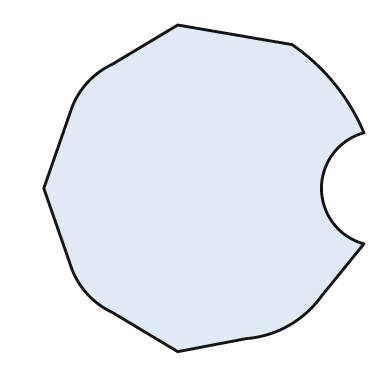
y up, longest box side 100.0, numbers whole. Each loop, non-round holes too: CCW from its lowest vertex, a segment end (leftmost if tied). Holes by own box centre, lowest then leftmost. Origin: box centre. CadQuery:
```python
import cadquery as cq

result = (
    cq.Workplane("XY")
    .moveTo(-8.0, -50.0)
    .lineTo(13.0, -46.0)
    .threePointArc((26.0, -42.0), (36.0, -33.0))
    .lineTo(49.0, -17.0)
    .threePointArc((36.0, 0.0), (49.0, 17.0))
    .threePointArc((40.0, 32.0), (27.0, 44.0))
    .lineTo(-8.0, 50.0)
    .lineTo(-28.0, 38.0)
    .threePointArc((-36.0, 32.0), (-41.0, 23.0))
    .lineTo(-49.0, 0.0)
    .lineTo(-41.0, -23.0)
    .threePointArc((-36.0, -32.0), (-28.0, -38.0))
    .close()
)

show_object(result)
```